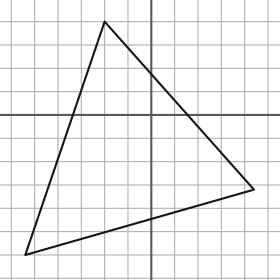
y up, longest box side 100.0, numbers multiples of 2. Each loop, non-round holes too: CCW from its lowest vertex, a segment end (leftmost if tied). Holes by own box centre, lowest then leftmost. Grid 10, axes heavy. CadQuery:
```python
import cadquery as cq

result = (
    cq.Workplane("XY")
    .moveTo(-54.0, -60.0)
    .lineTo(44.0, -32.0)
    .lineTo(-20.0, 40.0)
    .close()
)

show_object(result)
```